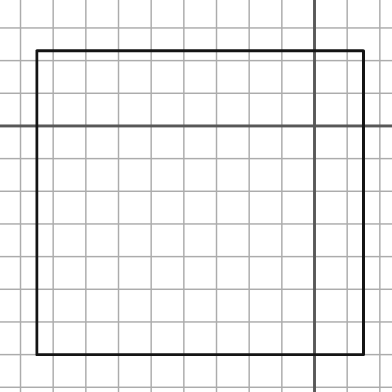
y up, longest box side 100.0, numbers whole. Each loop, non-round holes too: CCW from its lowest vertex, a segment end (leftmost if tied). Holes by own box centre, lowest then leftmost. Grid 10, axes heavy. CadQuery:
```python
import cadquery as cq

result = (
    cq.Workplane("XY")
    .moveTo(-85.0, -70.0)
    .lineTo(15.0, -70.0)
    .lineTo(15.0, 23.0)
    .lineTo(-85.0, 23.0)
    .close()
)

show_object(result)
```